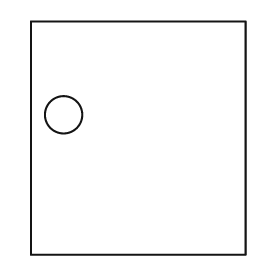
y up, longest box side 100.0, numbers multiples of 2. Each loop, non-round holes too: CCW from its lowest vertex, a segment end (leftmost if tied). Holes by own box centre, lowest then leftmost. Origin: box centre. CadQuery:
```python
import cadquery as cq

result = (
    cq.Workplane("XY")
    .moveTo(-46.0, -50.0)
    .lineTo(46.0, -50.0)
    .lineTo(46.0, 50.0)
    .lineTo(-46.0, 50.0)
    .close()
    .moveTo(-32.0, 10.0)
    .circle(8.0)
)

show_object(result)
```